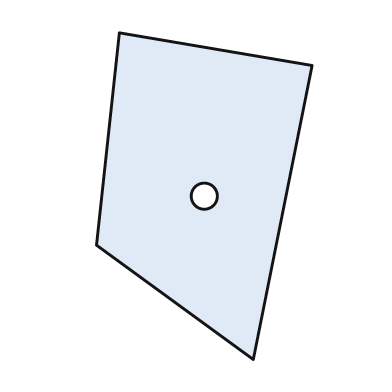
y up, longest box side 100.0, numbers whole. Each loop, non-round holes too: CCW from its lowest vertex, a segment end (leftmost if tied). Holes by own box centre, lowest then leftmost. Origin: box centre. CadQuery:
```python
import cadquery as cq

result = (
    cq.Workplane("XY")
    .moveTo(15.0, -50.0)
    .lineTo(33.0, 40.0)
    .lineTo(-26.0, 50.0)
    .lineTo(-33.0, -15.0)
    .close()
    .moveTo(0.0, 0.0)
    .circle(4.0)
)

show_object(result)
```